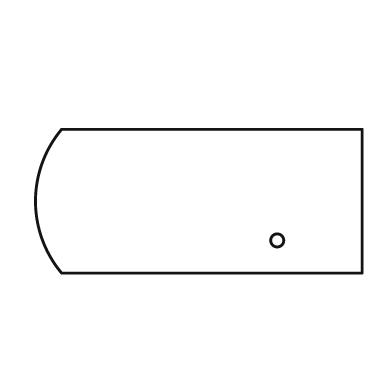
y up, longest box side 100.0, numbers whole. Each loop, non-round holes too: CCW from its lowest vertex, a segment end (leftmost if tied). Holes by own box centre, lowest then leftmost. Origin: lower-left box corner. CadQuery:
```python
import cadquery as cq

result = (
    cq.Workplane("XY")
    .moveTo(8.0, 0.0)
    .lineTo(100.0, 0.0)
    .lineTo(100.0, 44.0)
    .lineTo(8.0, 44.0)
    .threePointArc((0.0, 22.0), (8.0, 0.0))
    .close()
    .moveTo(74.0, 10.0)
    .circle(2.0)
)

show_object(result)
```